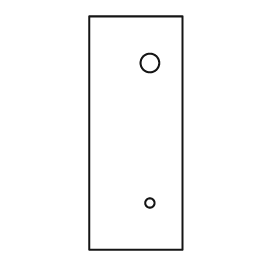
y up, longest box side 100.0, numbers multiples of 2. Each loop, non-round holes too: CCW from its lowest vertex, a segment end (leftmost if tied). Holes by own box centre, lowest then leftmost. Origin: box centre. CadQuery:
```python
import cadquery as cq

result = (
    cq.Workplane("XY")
    .moveTo(-20.0, -50.0)
    .lineTo(20.0, -50.0)
    .lineTo(20.0, 50.0)
    .lineTo(-20.0, 50.0)
    .close()
    .moveTo(6.0, -30.0)
    .circle(2.0)
    .moveTo(6.0, 30.0)
    .circle(4.0)
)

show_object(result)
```